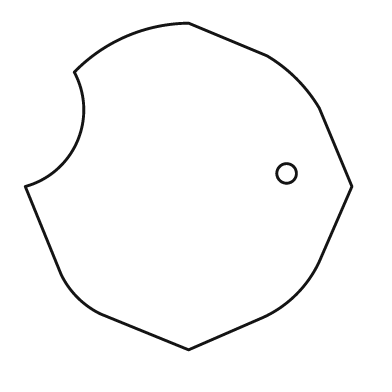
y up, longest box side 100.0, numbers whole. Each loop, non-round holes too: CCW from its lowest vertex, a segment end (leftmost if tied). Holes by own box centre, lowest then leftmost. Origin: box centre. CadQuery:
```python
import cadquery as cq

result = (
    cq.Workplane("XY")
    .moveTo(0.0, -50.0)
    .lineTo(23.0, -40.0)
    .threePointArc((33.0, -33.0), (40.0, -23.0))
    .lineTo(50.0, 0.0)
    .lineTo(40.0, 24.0)
    .threePointArc((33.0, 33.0), (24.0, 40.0))
    .lineTo(0.0, 50.0)
    .threePointArc((-19.0, 46.0), (-35.0, 35.0))
    .threePointArc((-34.0, 14.0), (-50.0, 0.0))
    .lineTo(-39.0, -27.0)
    .threePointArc((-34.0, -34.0), (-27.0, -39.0))
    .close()
    .moveTo(30.0, 4.0)
    .circle(3.0)
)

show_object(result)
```